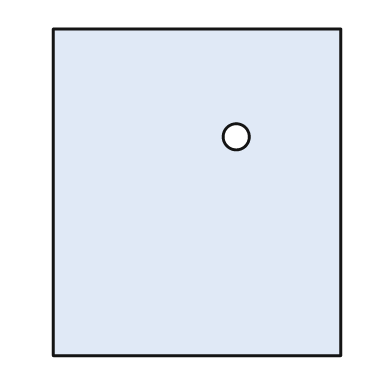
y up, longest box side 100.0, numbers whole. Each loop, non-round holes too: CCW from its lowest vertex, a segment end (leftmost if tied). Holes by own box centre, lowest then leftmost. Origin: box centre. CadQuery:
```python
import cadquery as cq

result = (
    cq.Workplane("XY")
    .moveTo(-44.0, -50.0)
    .lineTo(44.0, -50.0)
    .lineTo(44.0, 50.0)
    .lineTo(-44.0, 50.0)
    .close()
    .moveTo(12.0, 17.0)
    .circle(4.0)
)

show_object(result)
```